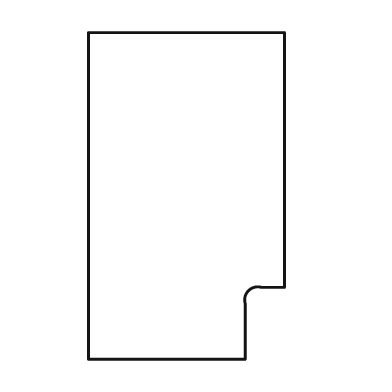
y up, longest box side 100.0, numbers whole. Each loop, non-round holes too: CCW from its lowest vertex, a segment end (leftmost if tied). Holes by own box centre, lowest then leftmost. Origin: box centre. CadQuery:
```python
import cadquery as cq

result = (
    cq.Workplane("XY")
    .moveTo(-30.0, -50.0)
    .lineTo(18.0, -50.0)
    .lineTo(18.0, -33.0)
    .threePointArc((19.0, -29.0), (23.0, -28.0))
    .lineTo(30.0, -28.0)
    .lineTo(30.0, 50.0)
    .lineTo(-30.0, 50.0)
    .close()
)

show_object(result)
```